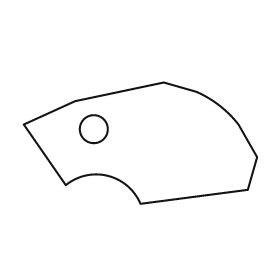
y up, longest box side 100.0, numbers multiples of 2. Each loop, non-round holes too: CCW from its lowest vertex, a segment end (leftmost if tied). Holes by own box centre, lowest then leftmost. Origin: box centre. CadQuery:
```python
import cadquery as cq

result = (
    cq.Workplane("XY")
    .moveTo(0.0, -26.0)
    .lineTo(46.0, -20.0)
    .lineTo(50.0, -6.0)
    .lineTo(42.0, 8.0)
    .threePointArc((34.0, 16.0), (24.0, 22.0))
    .lineTo(10.0, 26.0)
    .lineTo(-28.0, 18.0)
    .lineTo(-50.0, 8.0)
    .lineTo(-32.0, -18.0)
    .threePointArc((-14.0, -14.0), (0.0, -26.0))
    .close()
    .moveTo(-20.0, 6.0)
    .circle(6.0)
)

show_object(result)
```